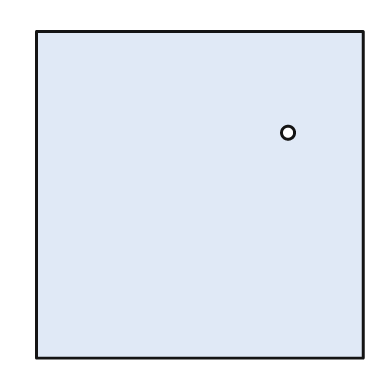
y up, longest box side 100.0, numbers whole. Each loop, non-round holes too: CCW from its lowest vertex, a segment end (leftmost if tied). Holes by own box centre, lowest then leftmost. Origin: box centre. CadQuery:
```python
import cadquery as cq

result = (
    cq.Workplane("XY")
    .moveTo(-50.0, -50.0)
    .lineTo(50.0, -50.0)
    .lineTo(50.0, 50.0)
    .lineTo(-50.0, 50.0)
    .close()
    .moveTo(27.0, 19.0)
    .circle(2.0)
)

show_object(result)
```